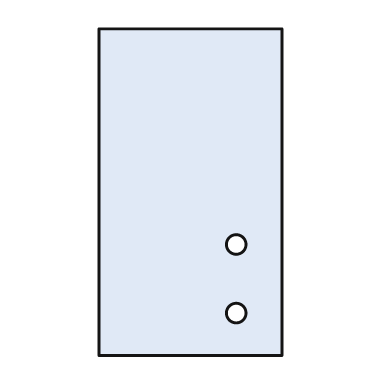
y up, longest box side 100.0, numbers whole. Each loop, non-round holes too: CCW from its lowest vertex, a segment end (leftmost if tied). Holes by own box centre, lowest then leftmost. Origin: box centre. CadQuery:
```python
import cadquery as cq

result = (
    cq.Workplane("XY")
    .moveTo(-28.0, -50.0)
    .lineTo(28.0, -50.0)
    .lineTo(28.0, 50.0)
    .lineTo(-28.0, 50.0)
    .close()
    .moveTo(14.0, -37.0)
    .circle(3.0)
    .moveTo(14.0, -16.0)
    .circle(3.0)
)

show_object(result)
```